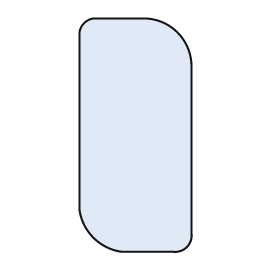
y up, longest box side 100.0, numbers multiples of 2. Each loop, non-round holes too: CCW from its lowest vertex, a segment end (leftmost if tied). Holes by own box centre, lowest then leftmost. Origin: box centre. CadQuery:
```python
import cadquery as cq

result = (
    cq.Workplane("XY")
    .moveTo(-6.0, -50.0)
    .lineTo(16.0, -50.0)
    .threePointArc((22.0, -48.0), (24.0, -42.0))
    .lineTo(24.0, 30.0)
    .threePointArc((18.0, 44.0), (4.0, 50.0))
    .lineTo(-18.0, 50.0)
    .threePointArc((-22.0, 48.0), (-24.0, 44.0))
    .lineTo(-24.0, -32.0)
    .threePointArc((-18.0, -44.0), (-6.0, -50.0))
    .close()
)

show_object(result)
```